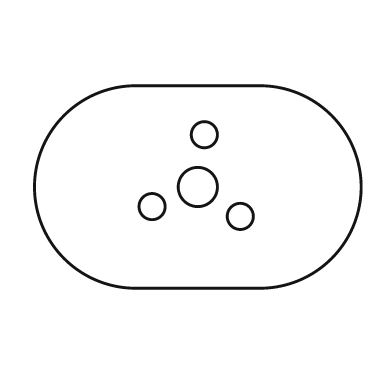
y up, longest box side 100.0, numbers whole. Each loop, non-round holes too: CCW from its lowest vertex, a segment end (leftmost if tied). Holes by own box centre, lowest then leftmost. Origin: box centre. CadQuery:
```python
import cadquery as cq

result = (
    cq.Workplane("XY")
    .moveTo(-19.0, -31.0)
    .lineTo(19.0, -31.0)
    .threePointArc((50.0, 0.0), (19.0, 31.0))
    .lineTo(-19.0, 31.0)
    .threePointArc((-50.0, 0.0), (-19.0, -31.0))
    .close()
    .moveTo(13.0, -9.0)
    .circle(4.0)
    .moveTo(-14.0, -6.0)
    .circle(4.0)
    .moveTo(0.0, 0.0)
    .circle(6.0)
    .moveTo(2.0, 16.0)
    .circle(4.0)
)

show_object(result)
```